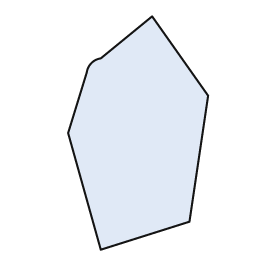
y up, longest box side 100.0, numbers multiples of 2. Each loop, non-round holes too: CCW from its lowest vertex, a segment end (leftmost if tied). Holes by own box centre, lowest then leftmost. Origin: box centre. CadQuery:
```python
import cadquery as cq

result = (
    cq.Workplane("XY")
    .moveTo(-16.0, -50.0)
    .lineTo(22.0, -38.0)
    .lineTo(30.0, 16.0)
    .lineTo(6.0, 50.0)
    .lineTo(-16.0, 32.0)
    .threePointArc((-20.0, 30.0), (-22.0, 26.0))
    .lineTo(-30.0, 0.0)
    .close()
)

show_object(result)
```